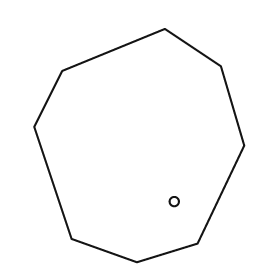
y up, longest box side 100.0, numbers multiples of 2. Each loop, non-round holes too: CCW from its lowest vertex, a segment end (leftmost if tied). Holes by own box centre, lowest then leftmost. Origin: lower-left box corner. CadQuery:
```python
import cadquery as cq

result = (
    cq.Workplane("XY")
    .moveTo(44.0, 0.0)
    .lineTo(70.0, 8.0)
    .lineTo(90.0, 50.0)
    .lineTo(80.0, 84.0)
    .lineTo(56.0, 100.0)
    .lineTo(12.0, 82.0)
    .lineTo(0.0, 58.0)
    .lineTo(16.0, 10.0)
    .close()
    .moveTo(60.0, 26.0)
    .circle(2.0)
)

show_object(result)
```